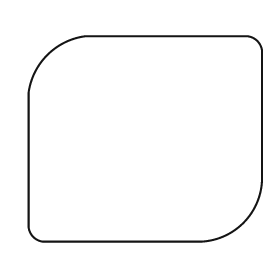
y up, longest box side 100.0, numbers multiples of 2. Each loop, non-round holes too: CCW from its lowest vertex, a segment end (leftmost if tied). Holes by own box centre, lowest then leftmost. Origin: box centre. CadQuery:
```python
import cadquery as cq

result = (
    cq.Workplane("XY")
    .moveTo(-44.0, -44.0)
    .lineTo(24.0, -44.0)
    .threePointArc((42.0, -36.0), (50.0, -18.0))
    .lineTo(50.0, 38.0)
    .threePointArc((48.0, 42.0), (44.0, 44.0))
    .lineTo(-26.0, 44.0)
    .threePointArc((-42.0, 36.0), (-50.0, 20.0))
    .lineTo(-50.0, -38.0)
    .threePointArc((-48.0, -42.0), (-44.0, -44.0))
    .close()
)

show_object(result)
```